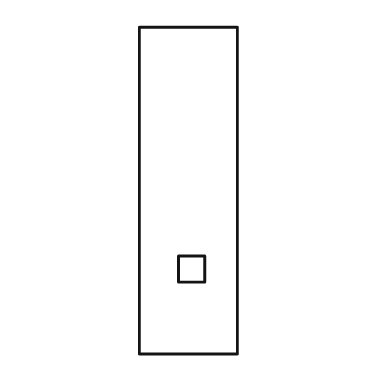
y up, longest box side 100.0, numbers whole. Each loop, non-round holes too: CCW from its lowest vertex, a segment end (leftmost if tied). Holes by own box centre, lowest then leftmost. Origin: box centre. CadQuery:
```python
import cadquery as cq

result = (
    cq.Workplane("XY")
    .moveTo(-15.0, -50.0)
    .lineTo(15.0, -50.0)
    .lineTo(15.0, 50.0)
    .lineTo(-15.0, 50.0)
    .close()
    .moveTo(-3.0, -28.0)
    .lineTo(5.0, -28.0)
    .lineTo(5.0, -20.0)
    .lineTo(-3.0, -20.0)
    .close()
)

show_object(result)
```